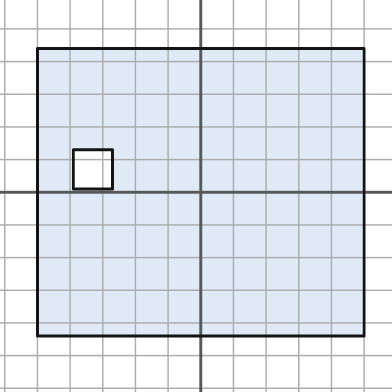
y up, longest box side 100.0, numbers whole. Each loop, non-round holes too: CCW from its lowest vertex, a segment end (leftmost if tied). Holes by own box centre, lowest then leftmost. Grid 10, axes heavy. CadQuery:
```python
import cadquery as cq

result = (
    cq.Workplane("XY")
    .moveTo(-50.0, -44.0)
    .lineTo(50.0, -44.0)
    .lineTo(50.0, 44.0)
    .lineTo(-50.0, 44.0)
    .close()
    .moveTo(-39.0, 1.0)
    .lineTo(-27.0, 1.0)
    .lineTo(-27.0, 13.0)
    .lineTo(-39.0, 13.0)
    .close()
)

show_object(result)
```